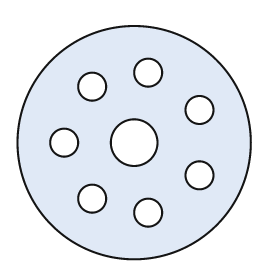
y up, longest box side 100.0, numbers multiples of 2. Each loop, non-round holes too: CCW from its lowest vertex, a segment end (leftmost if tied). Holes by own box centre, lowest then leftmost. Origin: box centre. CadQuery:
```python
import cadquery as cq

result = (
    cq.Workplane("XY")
    .moveTo(0.0, 0.0)
    .circle(50.0)
    .moveTo(6.0, -30.0)
    .circle(6.0)
    .moveTo(-18.0, -24.0)
    .circle(6.0)
    .moveTo(28.0, -14.0)
    .circle(6.0)
    .moveTo(-30.0, 0.0)
    .circle(6.0)
    .moveTo(0.0, 0.0)
    .circle(10.0)
    .moveTo(28.0, 14.0)
    .circle(6.0)
    .moveTo(-18.0, 24.0)
    .circle(6.0)
    .moveTo(6.0, 30.0)
    .circle(6.0)
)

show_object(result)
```